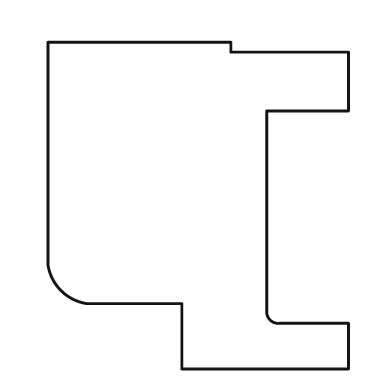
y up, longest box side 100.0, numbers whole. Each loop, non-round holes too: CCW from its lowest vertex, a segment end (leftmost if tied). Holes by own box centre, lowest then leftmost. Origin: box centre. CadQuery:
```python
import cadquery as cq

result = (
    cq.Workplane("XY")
    .moveTo(-5.0, -50.0)
    .lineTo(46.0, -50.0)
    .lineTo(46.0, -36.0)
    .lineTo(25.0, -36.0)
    .threePointArc((22.0, -35.0), (21.0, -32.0))
    .lineTo(21.0, 29.0)
    .lineTo(46.0, 29.0)
    .lineTo(46.0, 47.0)
    .lineTo(10.0, 47.0)
    .lineTo(10.0, 50.0)
    .lineTo(-46.0, 50.0)
    .lineTo(-46.0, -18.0)
    .threePointArc((-42.0, -26.0), (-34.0, -30.0))
    .lineTo(-5.0, -30.0)
    .close()
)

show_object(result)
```